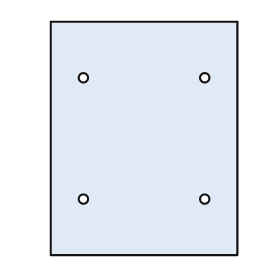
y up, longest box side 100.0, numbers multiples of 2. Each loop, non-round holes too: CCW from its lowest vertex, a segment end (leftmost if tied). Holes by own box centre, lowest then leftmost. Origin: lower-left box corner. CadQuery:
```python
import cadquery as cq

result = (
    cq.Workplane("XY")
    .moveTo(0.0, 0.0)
    .lineTo(80.0, 0.0)
    .lineTo(80.0, 100.0)
    .lineTo(0.0, 100.0)
    .close()
    .moveTo(14.0, 24.0)
    .circle(2.0)
    .moveTo(66.0, 24.0)
    .circle(2.0)
    .moveTo(14.0, 76.0)
    .circle(2.0)
    .moveTo(66.0, 76.0)
    .circle(2.0)
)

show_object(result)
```